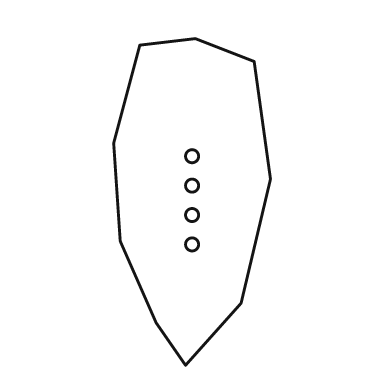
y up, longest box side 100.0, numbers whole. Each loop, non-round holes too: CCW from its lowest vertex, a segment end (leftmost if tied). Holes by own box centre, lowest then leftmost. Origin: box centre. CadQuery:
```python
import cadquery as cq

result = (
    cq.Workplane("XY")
    .moveTo(-2.0, -50.0)
    .lineTo(15.0, -31.0)
    .lineTo(24.0, 7.0)
    .lineTo(19.0, 43.0)
    .lineTo(1.0, 50.0)
    .lineTo(-16.0, 48.0)
    .lineTo(-24.0, 18.0)
    .lineTo(-22.0, -12.0)
    .lineTo(-11.0, -37.0)
    .close()
    .moveTo(0.0, -13.0)
    .circle(2.0)
    .moveTo(0.0, -4.0)
    .circle(2.0)
    .moveTo(0.0, 5.0)
    .circle(2.0)
    .moveTo(0.0, 14.0)
    .circle(2.0)
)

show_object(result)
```